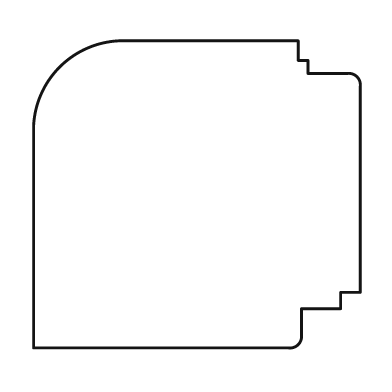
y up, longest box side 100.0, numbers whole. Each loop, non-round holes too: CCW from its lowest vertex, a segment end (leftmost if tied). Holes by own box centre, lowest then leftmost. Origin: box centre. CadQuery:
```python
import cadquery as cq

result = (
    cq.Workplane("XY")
    .moveTo(-50.0, -47.0)
    .lineTo(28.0, -47.0)
    .threePointArc((31.0, -46.0), (32.0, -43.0))
    .lineTo(32.0, -35.0)
    .lineTo(44.0, -35.0)
    .lineTo(44.0, -30.0)
    .lineTo(50.0, -30.0)
    .lineTo(50.0, 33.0)
    .threePointArc((49.0, 36.0), (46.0, 37.0))
    .lineTo(34.0, 37.0)
    .lineTo(34.0, 41.0)
    .lineTo(31.0, 41.0)
    .lineTo(31.0, 47.0)
    .lineTo(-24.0, 47.0)
    .threePointArc((-42.0, 39.0), (-50.0, 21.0))
    .close()
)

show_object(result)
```